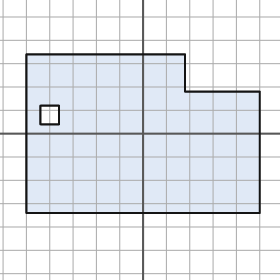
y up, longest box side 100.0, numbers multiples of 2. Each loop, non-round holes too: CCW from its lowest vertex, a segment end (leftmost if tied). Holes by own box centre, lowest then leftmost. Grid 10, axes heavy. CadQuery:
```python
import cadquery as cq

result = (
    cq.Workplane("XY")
    .moveTo(-50.0, -34.0)
    .lineTo(50.0, -34.0)
    .lineTo(50.0, 18.0)
    .lineTo(18.0, 18.0)
    .lineTo(18.0, 34.0)
    .lineTo(-50.0, 34.0)
    .close()
    .moveTo(-44.0, 4.0)
    .lineTo(-36.0, 4.0)
    .lineTo(-36.0, 12.0)
    .lineTo(-44.0, 12.0)
    .close()
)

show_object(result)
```